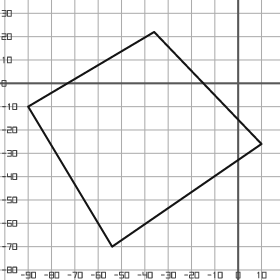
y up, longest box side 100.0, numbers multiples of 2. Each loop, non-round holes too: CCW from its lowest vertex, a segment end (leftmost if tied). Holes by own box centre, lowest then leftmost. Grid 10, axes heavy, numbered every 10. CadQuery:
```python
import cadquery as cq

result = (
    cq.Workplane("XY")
    .moveTo(-54.0, -70.0)
    .lineTo(10.0, -26.0)
    .lineTo(-36.0, 22.0)
    .lineTo(-90.0, -10.0)
    .close()
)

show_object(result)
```